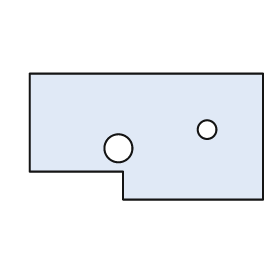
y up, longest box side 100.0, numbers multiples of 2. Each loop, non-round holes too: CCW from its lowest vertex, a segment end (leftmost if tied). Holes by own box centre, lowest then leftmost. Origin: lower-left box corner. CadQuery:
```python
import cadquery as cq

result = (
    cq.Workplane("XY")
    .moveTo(40.0, 0.0)
    .lineTo(100.0, 0.0)
    .lineTo(100.0, 54.0)
    .lineTo(0.0, 54.0)
    .lineTo(0.0, 12.0)
    .lineTo(40.0, 12.0)
    .close()
    .moveTo(38.0, 22.0)
    .circle(6.0)
    .moveTo(76.0, 30.0)
    .circle(4.0)
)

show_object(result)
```